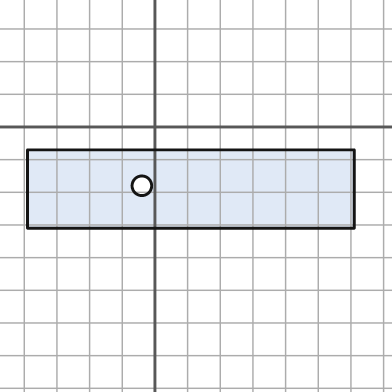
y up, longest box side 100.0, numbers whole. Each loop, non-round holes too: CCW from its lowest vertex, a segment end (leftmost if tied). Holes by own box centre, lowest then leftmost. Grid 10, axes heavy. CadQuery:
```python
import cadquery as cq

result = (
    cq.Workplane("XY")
    .moveTo(-39.0, -31.0)
    .lineTo(61.0, -31.0)
    .lineTo(61.0, -7.0)
    .lineTo(-39.0, -7.0)
    .close()
    .moveTo(-4.0, -18.0)
    .circle(3.0)
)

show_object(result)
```